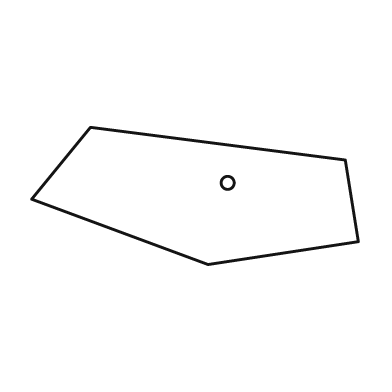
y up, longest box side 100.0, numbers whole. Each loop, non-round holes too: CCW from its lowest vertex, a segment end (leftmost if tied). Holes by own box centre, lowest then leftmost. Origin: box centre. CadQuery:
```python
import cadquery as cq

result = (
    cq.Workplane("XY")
    .moveTo(4.0, -21.0)
    .lineTo(50.0, -14.0)
    .lineTo(46.0, 11.0)
    .lineTo(-32.0, 21.0)
    .lineTo(-50.0, -1.0)
    .close()
    .moveTo(10.0, 4.0)
    .circle(2.0)
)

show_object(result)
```